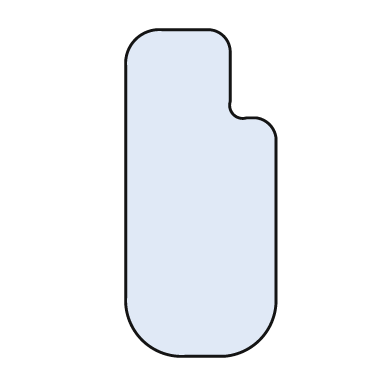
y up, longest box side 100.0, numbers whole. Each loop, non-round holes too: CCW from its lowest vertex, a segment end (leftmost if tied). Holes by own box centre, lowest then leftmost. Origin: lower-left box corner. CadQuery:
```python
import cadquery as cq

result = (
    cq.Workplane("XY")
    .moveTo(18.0, 0.0)
    .lineTo(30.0, 0.0)
    .threePointArc((41.0, 5.0), (46.0, 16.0))
    .lineTo(46.0, 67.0)
    .threePointArc((44.0, 71.0), (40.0, 73.0))
    .lineTo(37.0, 73.0)
    .threePointArc((33.0, 74.0), (32.0, 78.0))
    .lineTo(32.0, 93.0)
    .threePointArc((30.0, 98.0), (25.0, 100.0))
    .lineTo(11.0, 100.0)
    .threePointArc((3.0, 97.0), (0.0, 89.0))
    .lineTo(0.0, 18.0)
    .threePointArc((5.0, 5.0), (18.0, 0.0))
    .close()
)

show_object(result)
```